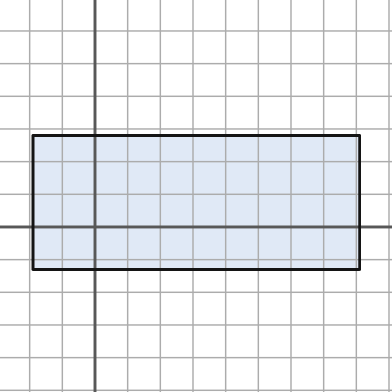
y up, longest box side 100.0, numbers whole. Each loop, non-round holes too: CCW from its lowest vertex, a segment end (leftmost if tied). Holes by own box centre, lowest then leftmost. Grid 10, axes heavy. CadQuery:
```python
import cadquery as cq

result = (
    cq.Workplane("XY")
    .moveTo(-19.0, -13.0)
    .lineTo(81.0, -13.0)
    .lineTo(81.0, 28.0)
    .lineTo(-19.0, 28.0)
    .close()
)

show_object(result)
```